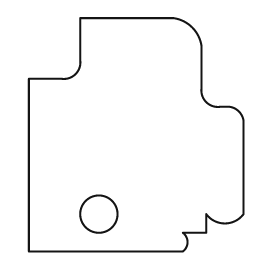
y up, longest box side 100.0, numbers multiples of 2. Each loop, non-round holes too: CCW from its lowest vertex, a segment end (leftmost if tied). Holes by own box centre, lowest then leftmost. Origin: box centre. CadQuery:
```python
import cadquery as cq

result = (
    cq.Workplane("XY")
    .moveTo(-46.0, -50.0)
    .lineTo(20.0, -50.0)
    .threePointArc((22.0, -46.0), (20.0, -42.0))
    .lineTo(30.0, -42.0)
    .lineTo(30.0, -34.0)
    .threePointArc((38.0, -38.0), (46.0, -34.0))
    .lineTo(46.0, 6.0)
    .threePointArc((44.0, 10.0), (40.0, 12.0))
    .lineTo(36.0, 12.0)
    .threePointArc((30.0, 14.0), (28.0, 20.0))
    .lineTo(28.0, 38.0)
    .threePointArc((24.0, 46.0), (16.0, 50.0))
    .lineTo(-24.0, 50.0)
    .lineTo(-24.0, 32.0)
    .threePointArc((-26.0, 26.0), (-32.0, 24.0))
    .lineTo(-46.0, 24.0)
    .close()
    .moveTo(-16.0, -34.0)
    .circle(8.0)
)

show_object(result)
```